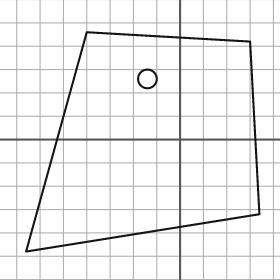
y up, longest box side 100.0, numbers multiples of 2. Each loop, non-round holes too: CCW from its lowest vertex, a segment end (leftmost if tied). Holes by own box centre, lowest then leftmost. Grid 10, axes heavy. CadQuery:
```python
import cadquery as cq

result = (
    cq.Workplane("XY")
    .moveTo(-66.0, -48.0)
    .lineTo(34.0, -32.0)
    .lineTo(30.0, 42.0)
    .lineTo(-40.0, 46.0)
    .close()
    .moveTo(-14.0, 26.0)
    .circle(4.0)
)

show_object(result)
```